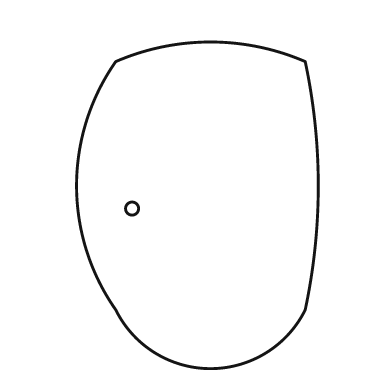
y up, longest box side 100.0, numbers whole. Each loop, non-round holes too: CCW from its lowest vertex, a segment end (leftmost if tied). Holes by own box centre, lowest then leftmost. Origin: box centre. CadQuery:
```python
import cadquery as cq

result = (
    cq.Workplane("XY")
    .moveTo(-25.0, -32.0)
    .threePointArc((4.0, -50.0), (33.0, -32.0))
    .threePointArc((37.0, 6.0), (33.0, 44.0))
    .threePointArc((4.0, 50.0), (-25.0, 44.0))
    .threePointArc((-37.0, 6.0), (-25.0, -32.0))
    .close()
    .moveTo(-20.0, -1.0)
    .circle(2.0)
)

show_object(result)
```